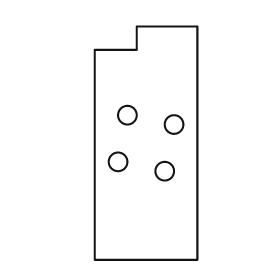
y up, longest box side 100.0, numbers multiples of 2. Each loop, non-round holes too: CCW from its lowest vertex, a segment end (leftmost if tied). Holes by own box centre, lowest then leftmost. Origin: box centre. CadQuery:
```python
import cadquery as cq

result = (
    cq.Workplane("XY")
    .moveTo(-22.0, -50.0)
    .lineTo(22.0, -50.0)
    .lineTo(22.0, 50.0)
    .lineTo(-4.0, 50.0)
    .lineTo(-4.0, 40.0)
    .lineTo(-22.0, 40.0)
    .close()
    .moveTo(8.0, -12.0)
    .circle(4.0)
    .moveTo(-12.0, -8.0)
    .circle(4.0)
    .moveTo(12.0, 8.0)
    .circle(4.0)
    .moveTo(-8.0, 12.0)
    .circle(4.0)
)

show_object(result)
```